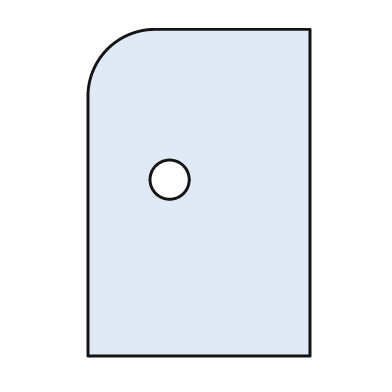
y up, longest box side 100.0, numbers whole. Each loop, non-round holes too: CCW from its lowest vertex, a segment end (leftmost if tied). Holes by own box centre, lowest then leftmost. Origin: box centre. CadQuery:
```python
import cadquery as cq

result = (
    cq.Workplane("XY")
    .moveTo(-34.0, -50.0)
    .lineTo(34.0, -50.0)
    .lineTo(34.0, 50.0)
    .lineTo(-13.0, 50.0)
    .threePointArc((-28.0, 44.0), (-34.0, 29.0))
    .close()
    .moveTo(-9.0, 4.0)
    .circle(6.0)
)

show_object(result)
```